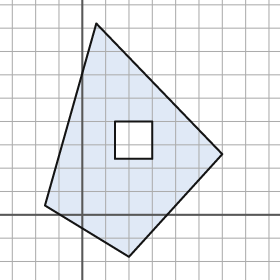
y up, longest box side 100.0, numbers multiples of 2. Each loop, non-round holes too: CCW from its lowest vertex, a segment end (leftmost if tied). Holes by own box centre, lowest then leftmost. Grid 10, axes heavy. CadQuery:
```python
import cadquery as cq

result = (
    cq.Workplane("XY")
    .moveTo(20.0, -18.0)
    .lineTo(60.0, 26.0)
    .lineTo(6.0, 82.0)
    .lineTo(-16.0, 4.0)
    .close()
    .moveTo(14.0, 24.0)
    .lineTo(30.0, 24.0)
    .lineTo(30.0, 40.0)
    .lineTo(14.0, 40.0)
    .close()
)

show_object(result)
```